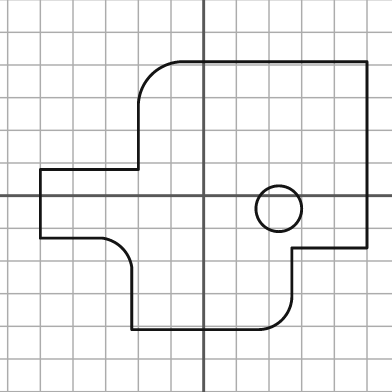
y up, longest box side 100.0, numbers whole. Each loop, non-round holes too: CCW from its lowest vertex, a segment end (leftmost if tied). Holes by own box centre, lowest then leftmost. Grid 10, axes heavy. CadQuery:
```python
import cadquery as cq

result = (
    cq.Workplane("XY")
    .moveTo(-22.0, -41.0)
    .lineTo(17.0, -41.0)
    .threePointArc((24.0, -38.0), (27.0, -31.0))
    .lineTo(27.0, -16.0)
    .lineTo(50.0, -16.0)
    .lineTo(50.0, 41.0)
    .lineTo(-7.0, 41.0)
    .threePointArc((-16.0, 37.0), (-20.0, 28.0))
    .lineTo(-20.0, 8.0)
    .lineTo(-50.0, 8.0)
    .lineTo(-50.0, -13.0)
    .lineTo(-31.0, -13.0)
    .threePointArc((-25.0, -16.0), (-22.0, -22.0))
    .close()
    .moveTo(23.0, -4.0)
    .circle(7.0)
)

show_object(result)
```